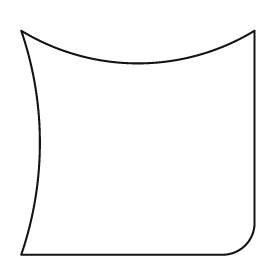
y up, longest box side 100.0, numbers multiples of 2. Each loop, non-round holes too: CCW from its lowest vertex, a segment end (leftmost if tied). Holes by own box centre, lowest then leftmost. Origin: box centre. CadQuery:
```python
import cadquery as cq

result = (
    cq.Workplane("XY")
    .moveTo(-50.0, -48.0)
    .lineTo(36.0, -48.0)
    .threePointArc((46.0, -44.0), (50.0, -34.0))
    .lineTo(50.0, 48.0)
    .threePointArc((0.0, 34.0), (-50.0, 48.0))
    .threePointArc((-42.0, 0.0), (-50.0, -48.0))
    .close()
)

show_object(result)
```